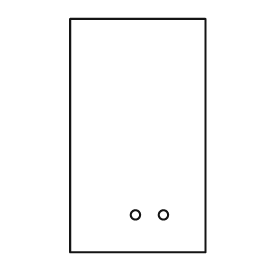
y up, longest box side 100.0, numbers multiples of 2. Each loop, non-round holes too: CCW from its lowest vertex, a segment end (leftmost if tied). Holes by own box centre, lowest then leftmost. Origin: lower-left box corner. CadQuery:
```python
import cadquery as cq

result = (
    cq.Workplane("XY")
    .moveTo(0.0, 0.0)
    .lineTo(58.0, 0.0)
    .lineTo(58.0, 100.0)
    .lineTo(0.0, 100.0)
    .close()
    .moveTo(28.0, 16.0)
    .circle(2.0)
    .moveTo(40.0, 16.0)
    .circle(2.0)
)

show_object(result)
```